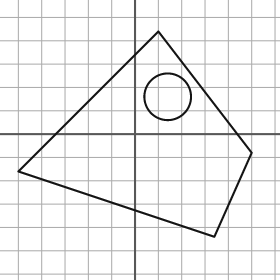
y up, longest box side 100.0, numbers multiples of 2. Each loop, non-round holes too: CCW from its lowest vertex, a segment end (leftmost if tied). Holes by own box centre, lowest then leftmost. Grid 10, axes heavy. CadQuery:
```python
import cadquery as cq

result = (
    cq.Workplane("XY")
    .moveTo(34.0, -44.0)
    .lineTo(50.0, -8.0)
    .lineTo(10.0, 44.0)
    .lineTo(-50.0, -16.0)
    .close()
    .moveTo(14.0, 16.0)
    .circle(10.0)
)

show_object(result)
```